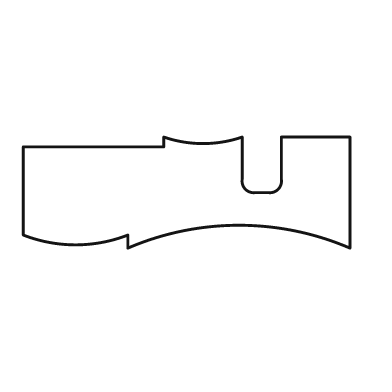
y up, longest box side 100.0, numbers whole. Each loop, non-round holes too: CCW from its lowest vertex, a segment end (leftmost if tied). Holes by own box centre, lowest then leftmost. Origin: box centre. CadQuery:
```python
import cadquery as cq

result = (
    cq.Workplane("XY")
    .moveTo(-18.0, -17.0)
    .threePointArc((16.0, -10.0), (50.0, -17.0))
    .lineTo(50.0, 17.0)
    .lineTo(29.0, 17.0)
    .lineTo(29.0, 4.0)
    .threePointArc((28.0, 1.0), (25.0, 0.0))
    .lineTo(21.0, 0.0)
    .threePointArc((18.0, 1.0), (17.0, 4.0))
    .lineTo(17.0, 17.0)
    .threePointArc((5.0, 15.0), (-7.0, 17.0))
    .lineTo(-7.0, 14.0)
    .lineTo(-50.0, 14.0)
    .lineTo(-50.0, -13.0)
    .threePointArc((-34.0, -16.0), (-18.0, -13.0))
    .close()
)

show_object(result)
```